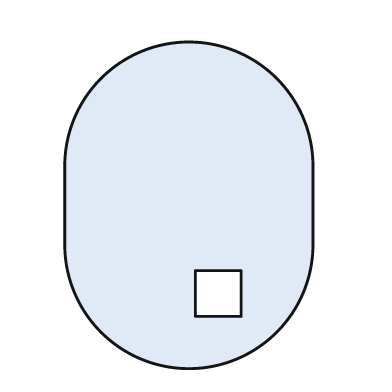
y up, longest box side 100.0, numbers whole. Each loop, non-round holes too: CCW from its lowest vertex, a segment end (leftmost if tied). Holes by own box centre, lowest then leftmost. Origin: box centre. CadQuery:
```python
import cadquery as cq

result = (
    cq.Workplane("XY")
    .moveTo(-38.0, -12.0)
    .threePointArc((0.0, -50.0), (38.0, -12.0))
    .lineTo(38.0, 12.0)
    .threePointArc((0.0, 50.0), (-38.0, 12.0))
    .close()
    .moveTo(2.0, -34.0)
    .lineTo(16.0, -34.0)
    .lineTo(16.0, -20.0)
    .lineTo(2.0, -20.0)
    .close()
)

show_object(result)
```